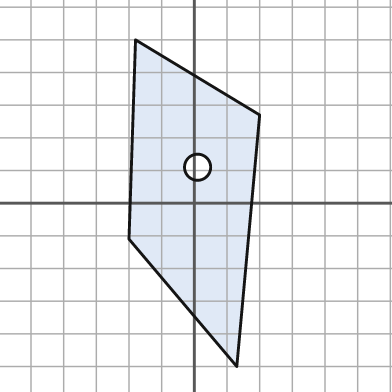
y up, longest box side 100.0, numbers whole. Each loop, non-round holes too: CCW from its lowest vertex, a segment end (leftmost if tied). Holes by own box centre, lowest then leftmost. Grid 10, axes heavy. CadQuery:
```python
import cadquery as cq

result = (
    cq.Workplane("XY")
    .moveTo(13.0, -50.0)
    .lineTo(20.0, 27.0)
    .lineTo(-18.0, 50.0)
    .lineTo(-20.0, -11.0)
    .close()
    .moveTo(1.0, 11.0)
    .circle(4.0)
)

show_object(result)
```